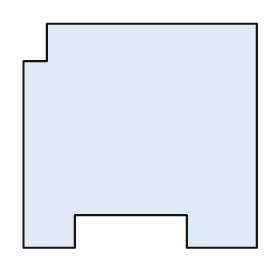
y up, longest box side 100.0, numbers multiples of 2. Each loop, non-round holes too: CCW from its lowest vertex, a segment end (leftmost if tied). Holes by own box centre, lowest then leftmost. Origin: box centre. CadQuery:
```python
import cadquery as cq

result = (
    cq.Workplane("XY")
    .moveTo(-50.0, -48.0)
    .lineTo(-28.0, -48.0)
    .lineTo(-28.0, -34.0)
    .lineTo(20.0, -34.0)
    .lineTo(20.0, -48.0)
    .lineTo(50.0, -48.0)
    .lineTo(50.0, 48.0)
    .lineTo(-40.0, 48.0)
    .lineTo(-40.0, 32.0)
    .lineTo(-50.0, 32.0)
    .close()
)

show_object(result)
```